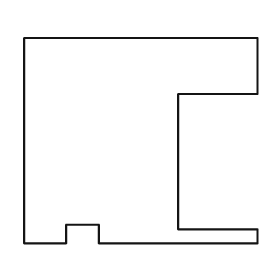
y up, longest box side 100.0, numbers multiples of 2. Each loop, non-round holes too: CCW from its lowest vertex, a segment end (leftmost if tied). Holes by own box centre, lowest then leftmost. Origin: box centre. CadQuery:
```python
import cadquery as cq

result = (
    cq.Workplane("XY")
    .moveTo(-50.0, -44.0)
    .lineTo(-32.0, -44.0)
    .lineTo(-32.0, -36.0)
    .lineTo(-18.0, -36.0)
    .lineTo(-18.0, -44.0)
    .lineTo(50.0, -44.0)
    .lineTo(50.0, -38.0)
    .lineTo(16.0, -38.0)
    .lineTo(16.0, 20.0)
    .lineTo(50.0, 20.0)
    .lineTo(50.0, 44.0)
    .lineTo(-50.0, 44.0)
    .close()
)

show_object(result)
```